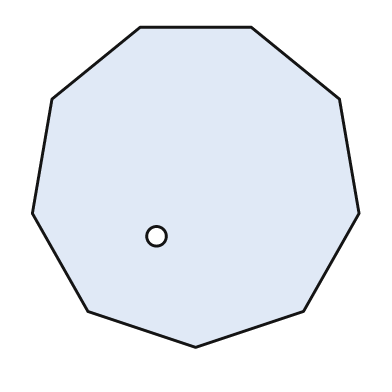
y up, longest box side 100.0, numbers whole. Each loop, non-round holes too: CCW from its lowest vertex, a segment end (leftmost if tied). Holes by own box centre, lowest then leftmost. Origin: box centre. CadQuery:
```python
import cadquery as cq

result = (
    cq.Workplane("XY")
    .moveTo(0.0, -49.0)
    .lineTo(33.0, -38.0)
    .lineTo(50.0, -8.0)
    .lineTo(44.0, 27.0)
    .lineTo(17.0, 49.0)
    .lineTo(-17.0, 49.0)
    .lineTo(-44.0, 27.0)
    .lineTo(-50.0, -8.0)
    .lineTo(-33.0, -38.0)
    .close()
    .moveTo(-12.0, -15.0)
    .circle(3.0)
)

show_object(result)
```